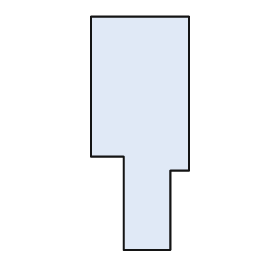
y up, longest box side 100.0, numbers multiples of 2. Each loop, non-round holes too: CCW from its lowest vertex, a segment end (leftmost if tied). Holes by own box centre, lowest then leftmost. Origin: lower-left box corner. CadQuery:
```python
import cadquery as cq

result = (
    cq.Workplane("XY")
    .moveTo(14.0, 0.0)
    .lineTo(34.0, 0.0)
    .lineTo(34.0, 34.0)
    .lineTo(42.0, 34.0)
    .lineTo(42.0, 100.0)
    .lineTo(0.0, 100.0)
    .lineTo(0.0, 40.0)
    .lineTo(14.0, 40.0)
    .close()
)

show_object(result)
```